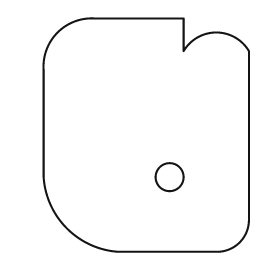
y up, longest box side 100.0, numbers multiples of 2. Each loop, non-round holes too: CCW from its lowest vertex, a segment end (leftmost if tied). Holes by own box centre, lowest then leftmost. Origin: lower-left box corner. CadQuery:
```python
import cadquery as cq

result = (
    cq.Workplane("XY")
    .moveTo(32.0, 0.0)
    .lineTo(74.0, 0.0)
    .threePointArc((84.0, 4.0), (88.0, 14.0))
    .lineTo(88.0, 86.0)
    .threePointArc((74.0, 94.0), (60.0, 86.0))
    .lineTo(60.0, 100.0)
    .lineTo(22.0, 100.0)
    .threePointArc((6.0, 94.0), (0.0, 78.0))
    .lineTo(0.0, 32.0)
    .threePointArc((10.0, 10.0), (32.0, 0.0))
    .close()
    .moveTo(54.0, 32.0)
    .circle(6.0)
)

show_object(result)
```